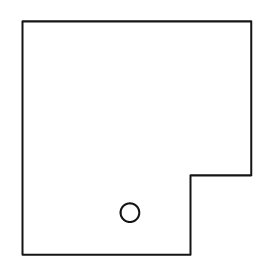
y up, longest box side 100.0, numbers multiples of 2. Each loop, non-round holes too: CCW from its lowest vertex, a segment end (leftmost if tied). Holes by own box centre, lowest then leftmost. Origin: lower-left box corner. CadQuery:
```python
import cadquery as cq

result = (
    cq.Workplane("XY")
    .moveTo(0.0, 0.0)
    .lineTo(72.0, 0.0)
    .lineTo(72.0, 34.0)
    .lineTo(98.0, 34.0)
    .lineTo(98.0, 100.0)
    .lineTo(0.0, 100.0)
    .close()
    .moveTo(46.0, 18.0)
    .circle(4.0)
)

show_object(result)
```